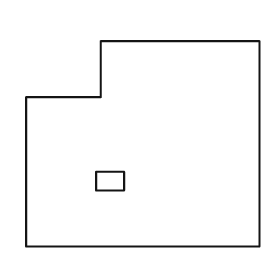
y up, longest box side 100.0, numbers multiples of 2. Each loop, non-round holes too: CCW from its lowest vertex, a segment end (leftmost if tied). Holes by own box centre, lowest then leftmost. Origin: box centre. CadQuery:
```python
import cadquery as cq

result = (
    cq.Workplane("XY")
    .moveTo(-50.0, -44.0)
    .lineTo(50.0, -44.0)
    .lineTo(50.0, 44.0)
    .lineTo(-18.0, 44.0)
    .lineTo(-18.0, 20.0)
    .lineTo(-50.0, 20.0)
    .close()
    .moveTo(-20.0, -20.0)
    .lineTo(-8.0, -20.0)
    .lineTo(-8.0, -12.0)
    .lineTo(-20.0, -12.0)
    .close()
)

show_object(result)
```